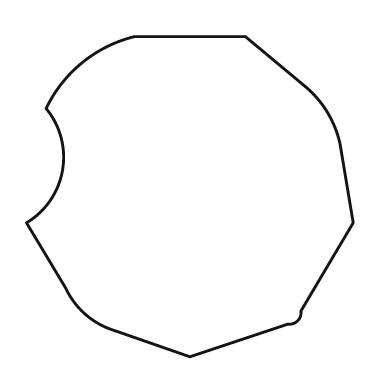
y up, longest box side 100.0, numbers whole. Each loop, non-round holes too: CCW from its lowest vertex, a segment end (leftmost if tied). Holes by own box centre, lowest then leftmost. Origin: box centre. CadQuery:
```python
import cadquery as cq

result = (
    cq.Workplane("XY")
    .moveTo(0.0, -49.0)
    .lineTo(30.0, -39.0)
    .threePointArc((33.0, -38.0), (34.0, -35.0))
    .lineTo(50.0, -8.0)
    .lineTo(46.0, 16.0)
    .threePointArc((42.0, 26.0), (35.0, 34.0))
    .lineTo(17.0, 49.0)
    .lineTo(-17.0, 49.0)
    .threePointArc((-33.0, 41.0), (-44.0, 27.0))
    .threePointArc((-39.0, 8.0), (-50.0, -8.0))
    .lineTo(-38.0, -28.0)
    .threePointArc((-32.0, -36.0), (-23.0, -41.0))
    .close()
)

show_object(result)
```